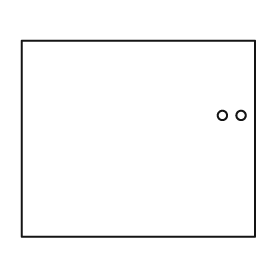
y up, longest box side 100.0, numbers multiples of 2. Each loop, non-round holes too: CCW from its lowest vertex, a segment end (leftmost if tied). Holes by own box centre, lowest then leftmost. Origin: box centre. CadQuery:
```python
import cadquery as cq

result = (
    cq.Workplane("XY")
    .moveTo(-50.0, -42.0)
    .lineTo(50.0, -42.0)
    .lineTo(50.0, 42.0)
    .lineTo(-50.0, 42.0)
    .close()
    .moveTo(36.0, 10.0)
    .circle(2.0)
    .moveTo(44.0, 10.0)
    .circle(2.0)
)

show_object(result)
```